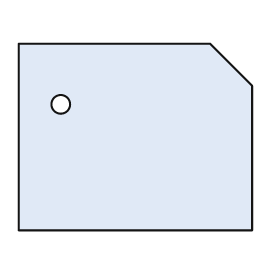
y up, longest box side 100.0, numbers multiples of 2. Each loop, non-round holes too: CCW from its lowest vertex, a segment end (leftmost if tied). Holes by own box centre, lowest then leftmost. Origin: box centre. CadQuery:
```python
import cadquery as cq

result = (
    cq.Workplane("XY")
    .moveTo(-50.0, -40.0)
    .lineTo(50.0, -40.0)
    .lineTo(50.0, 22.0)
    .lineTo(32.0, 40.0)
    .lineTo(-50.0, 40.0)
    .close()
    .moveTo(-32.0, 14.0)
    .circle(4.0)
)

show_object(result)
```